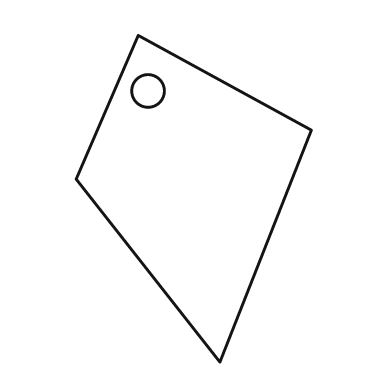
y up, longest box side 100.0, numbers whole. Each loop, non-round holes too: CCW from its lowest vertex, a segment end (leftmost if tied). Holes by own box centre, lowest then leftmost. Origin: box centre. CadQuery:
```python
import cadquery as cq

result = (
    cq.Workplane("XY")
    .moveTo(8.0, -50.0)
    .lineTo(36.0, 21.0)
    .lineTo(-17.0, 50.0)
    .lineTo(-36.0, 6.0)
    .close()
    .moveTo(-14.0, 33.0)
    .circle(5.0)
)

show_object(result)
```